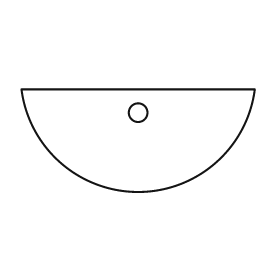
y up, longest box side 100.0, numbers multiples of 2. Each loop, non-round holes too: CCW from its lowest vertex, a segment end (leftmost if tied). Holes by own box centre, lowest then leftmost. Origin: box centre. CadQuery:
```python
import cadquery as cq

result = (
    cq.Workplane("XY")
    .moveTo(-50.0, 22.0)
    .threePointArc((0.0, -22.0), (50.0, 22.0))
    .close()
    .moveTo(0.0, 12.0)
    .circle(4.0)
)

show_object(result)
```